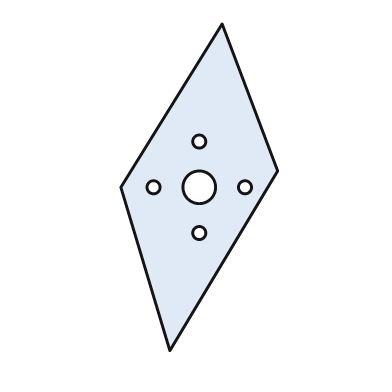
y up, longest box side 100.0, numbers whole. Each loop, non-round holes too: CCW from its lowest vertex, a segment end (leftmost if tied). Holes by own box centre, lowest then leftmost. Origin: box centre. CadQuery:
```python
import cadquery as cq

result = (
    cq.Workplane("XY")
    .moveTo(-9.0, -50.0)
    .lineTo(24.0, 5.0)
    .lineTo(7.0, 50.0)
    .lineTo(-24.0, 0.0)
    .close()
    .moveTo(0.0, -14.0)
    .circle(2.0)
    .moveTo(-14.0, 0.0)
    .circle(2.0)
    .moveTo(0.0, 0.0)
    .circle(5.0)
    .moveTo(14.0, 0.0)
    .circle(2.0)
    .moveTo(0.0, 14.0)
    .circle(2.0)
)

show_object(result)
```